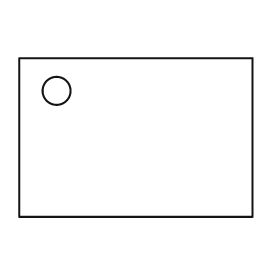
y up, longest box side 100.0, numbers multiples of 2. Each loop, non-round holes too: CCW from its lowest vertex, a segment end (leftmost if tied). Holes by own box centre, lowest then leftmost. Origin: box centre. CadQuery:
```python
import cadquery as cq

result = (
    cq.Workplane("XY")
    .moveTo(-50.0, -34.0)
    .lineTo(50.0, -34.0)
    .lineTo(50.0, 34.0)
    .lineTo(-50.0, 34.0)
    .close()
    .moveTo(-34.0, 20.0)
    .circle(6.0)
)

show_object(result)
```